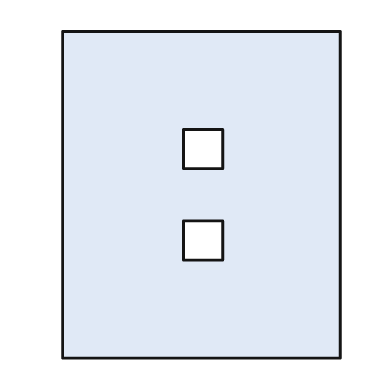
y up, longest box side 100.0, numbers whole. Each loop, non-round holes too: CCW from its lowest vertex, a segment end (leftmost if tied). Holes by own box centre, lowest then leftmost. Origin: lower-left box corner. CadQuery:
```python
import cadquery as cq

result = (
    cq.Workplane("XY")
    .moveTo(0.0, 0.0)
    .lineTo(85.0, 0.0)
    .lineTo(85.0, 100.0)
    .lineTo(0.0, 100.0)
    .close()
    .moveTo(37.0, 30.0)
    .lineTo(49.0, 30.0)
    .lineTo(49.0, 42.0)
    .lineTo(37.0, 42.0)
    .close()
    .moveTo(37.0, 58.0)
    .lineTo(49.0, 58.0)
    .lineTo(49.0, 70.0)
    .lineTo(37.0, 70.0)
    .close()
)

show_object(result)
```